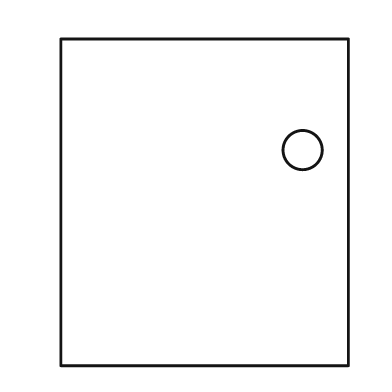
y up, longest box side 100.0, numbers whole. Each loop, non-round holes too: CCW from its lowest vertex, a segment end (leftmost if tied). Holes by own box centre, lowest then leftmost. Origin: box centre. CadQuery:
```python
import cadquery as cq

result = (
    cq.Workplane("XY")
    .moveTo(-44.0, -50.0)
    .lineTo(44.0, -50.0)
    .lineTo(44.0, 50.0)
    .lineTo(-44.0, 50.0)
    .close()
    .moveTo(30.0, 16.0)
    .circle(6.0)
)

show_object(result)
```